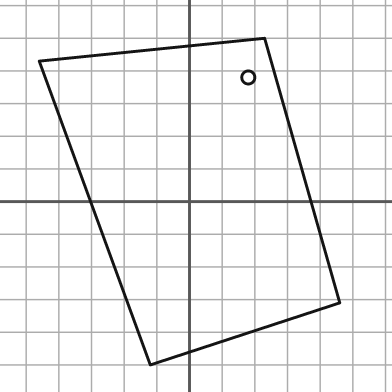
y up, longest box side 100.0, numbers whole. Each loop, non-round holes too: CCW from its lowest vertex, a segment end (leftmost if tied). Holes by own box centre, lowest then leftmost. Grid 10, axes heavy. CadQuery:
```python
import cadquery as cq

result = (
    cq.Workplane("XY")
    .moveTo(-12.0, -50.0)
    .lineTo(46.0, -31.0)
    .lineTo(23.0, 50.0)
    .lineTo(-46.0, 43.0)
    .close()
    .moveTo(18.0, 38.0)
    .circle(2.0)
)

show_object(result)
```